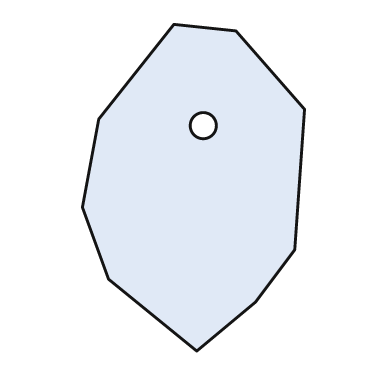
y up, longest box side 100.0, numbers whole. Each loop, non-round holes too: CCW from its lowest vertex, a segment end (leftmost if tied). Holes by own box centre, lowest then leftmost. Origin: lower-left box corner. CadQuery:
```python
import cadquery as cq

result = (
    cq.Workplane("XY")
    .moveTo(35.0, 0.0)
    .lineTo(53.0, 15.0)
    .lineTo(65.0, 31.0)
    .lineTo(68.0, 74.0)
    .lineTo(47.0, 98.0)
    .lineTo(28.0, 100.0)
    .lineTo(5.0, 71.0)
    .lineTo(0.0, 44.0)
    .lineTo(8.0, 22.0)
    .close()
    .moveTo(37.0, 69.0)
    .circle(4.0)
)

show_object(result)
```